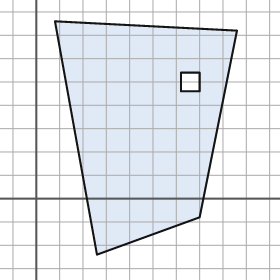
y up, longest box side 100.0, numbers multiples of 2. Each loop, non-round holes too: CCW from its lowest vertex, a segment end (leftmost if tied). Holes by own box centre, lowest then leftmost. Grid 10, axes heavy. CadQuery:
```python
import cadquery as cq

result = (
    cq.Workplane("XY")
    .moveTo(26.0, -24.0)
    .lineTo(70.0, -8.0)
    .lineTo(86.0, 72.0)
    .lineTo(8.0, 76.0)
    .close()
    .moveTo(62.0, 46.0)
    .lineTo(70.0, 46.0)
    .lineTo(70.0, 54.0)
    .lineTo(62.0, 54.0)
    .close()
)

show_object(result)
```